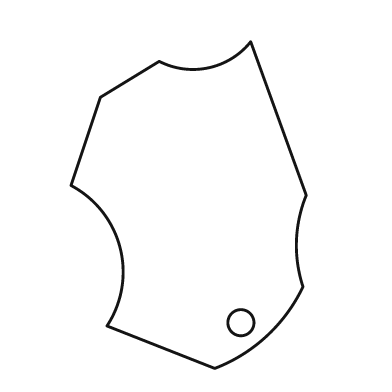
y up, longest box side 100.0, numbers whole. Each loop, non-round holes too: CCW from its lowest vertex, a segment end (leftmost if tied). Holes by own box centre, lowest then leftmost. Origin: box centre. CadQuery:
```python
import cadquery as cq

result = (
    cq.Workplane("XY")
    .moveTo(8.0, -50.0)
    .threePointArc((24.0, -40.0), (35.0, -25.0))
    .threePointArc((33.0, -11.0), (36.0, 3.0))
    .lineTo(19.0, 50.0)
    .threePointArc((6.0, 42.0), (-9.0, 44.0))
    .lineTo(-27.0, 33.0)
    .lineTo(-36.0, 6.0)
    .threePointArc((-21.0, -13.0), (-25.0, -37.0))
    .close()
    .moveTo(16.0, -36.0)
    .circle(4.0)
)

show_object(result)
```